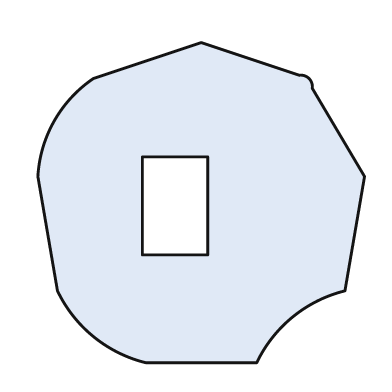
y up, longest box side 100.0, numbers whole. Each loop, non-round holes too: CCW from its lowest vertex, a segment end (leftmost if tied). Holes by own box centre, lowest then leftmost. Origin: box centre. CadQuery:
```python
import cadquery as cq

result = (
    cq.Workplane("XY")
    .moveTo(-17.0, -49.0)
    .lineTo(17.0, -49.0)
    .threePointArc((28.0, -35.0), (44.0, -27.0))
    .lineTo(50.0, 8.0)
    .lineTo(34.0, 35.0)
    .threePointArc((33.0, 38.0), (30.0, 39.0))
    .lineTo(0.0, 49.0)
    .lineTo(-33.0, 38.0)
    .threePointArc((-45.0, 25.0), (-50.0, 8.0))
    .lineTo(-44.0, -27.0)
    .threePointArc((-33.0, -41.0), (-17.0, -49.0))
    .close()
    .moveTo(-18.0, -16.0)
    .lineTo(2.0, -16.0)
    .lineTo(2.0, 14.0)
    .lineTo(-18.0, 14.0)
    .close()
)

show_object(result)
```